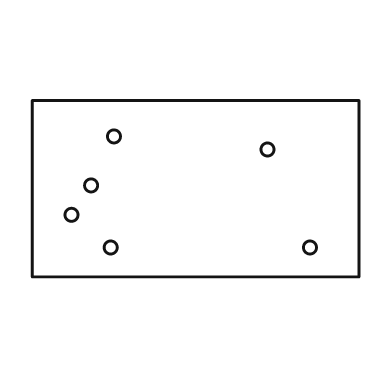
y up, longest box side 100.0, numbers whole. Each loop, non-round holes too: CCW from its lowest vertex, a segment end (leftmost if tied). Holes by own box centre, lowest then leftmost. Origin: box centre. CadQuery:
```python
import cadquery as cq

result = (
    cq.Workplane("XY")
    .moveTo(-50.0, -27.0)
    .lineTo(50.0, -27.0)
    .lineTo(50.0, 27.0)
    .lineTo(-50.0, 27.0)
    .close()
    .moveTo(-26.0, -18.0)
    .circle(2.0)
    .moveTo(35.0, -18.0)
    .circle(2.0)
    .moveTo(-38.0, -8.0)
    .circle(2.0)
    .moveTo(-32.0, 1.0)
    .circle(2.0)
    .moveTo(22.0, 12.0)
    .circle(2.0)
    .moveTo(-25.0, 16.0)
    .circle(2.0)
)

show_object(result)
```